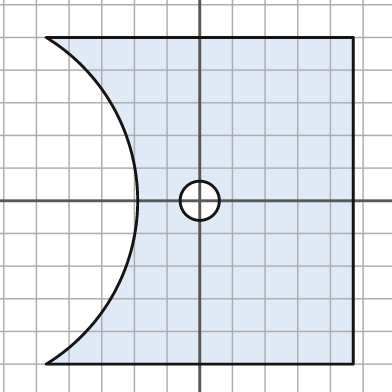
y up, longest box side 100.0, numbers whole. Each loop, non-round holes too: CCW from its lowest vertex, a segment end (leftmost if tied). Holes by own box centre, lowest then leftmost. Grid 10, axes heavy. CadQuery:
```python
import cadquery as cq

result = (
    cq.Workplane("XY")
    .moveTo(-47.0, -50.0)
    .lineTo(47.0, -50.0)
    .lineTo(47.0, 50.0)
    .lineTo(-47.0, 50.0)
    .threePointArc((-19.0, 0.0), (-47.0, -50.0))
    .close()
    .moveTo(0.0, 0.0)
    .circle(6.0)
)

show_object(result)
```